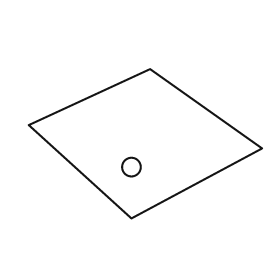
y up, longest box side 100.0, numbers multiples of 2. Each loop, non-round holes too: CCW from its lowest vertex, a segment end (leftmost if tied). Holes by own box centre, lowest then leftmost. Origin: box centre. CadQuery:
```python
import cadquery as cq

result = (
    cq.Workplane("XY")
    .moveTo(-6.0, -32.0)
    .lineTo(50.0, -2.0)
    .lineTo(2.0, 32.0)
    .lineTo(-50.0, 8.0)
    .close()
    .moveTo(-6.0, -10.0)
    .circle(4.0)
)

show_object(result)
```